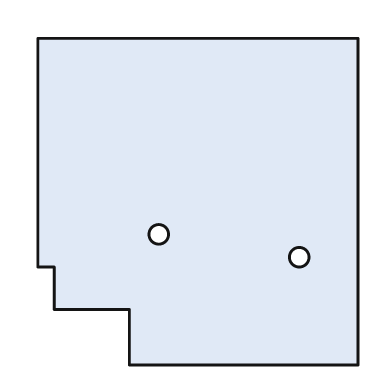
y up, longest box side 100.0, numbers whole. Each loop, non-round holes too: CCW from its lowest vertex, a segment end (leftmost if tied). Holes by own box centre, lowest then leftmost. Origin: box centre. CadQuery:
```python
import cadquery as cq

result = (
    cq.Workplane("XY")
    .moveTo(-21.0, -50.0)
    .lineTo(49.0, -50.0)
    .lineTo(49.0, 50.0)
    .lineTo(-49.0, 50.0)
    .lineTo(-49.0, -20.0)
    .lineTo(-44.0, -20.0)
    .lineTo(-44.0, -33.0)
    .lineTo(-21.0, -33.0)
    .close()
    .moveTo(31.0, -17.0)
    .circle(3.0)
    .moveTo(-12.0, -10.0)
    .circle(3.0)
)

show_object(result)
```